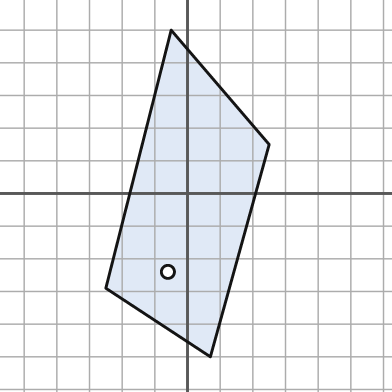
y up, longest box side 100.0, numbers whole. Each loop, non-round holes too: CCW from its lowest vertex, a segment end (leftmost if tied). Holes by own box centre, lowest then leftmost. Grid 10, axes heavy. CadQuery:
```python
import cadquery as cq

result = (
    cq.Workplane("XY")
    .moveTo(7.0, -50.0)
    .lineTo(25.0, 15.0)
    .lineTo(-5.0, 50.0)
    .lineTo(-25.0, -29.0)
    .close()
    .moveTo(-6.0, -24.0)
    .circle(2.0)
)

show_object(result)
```